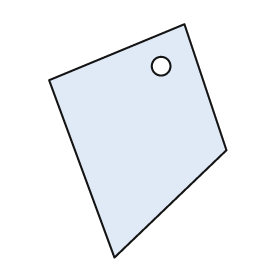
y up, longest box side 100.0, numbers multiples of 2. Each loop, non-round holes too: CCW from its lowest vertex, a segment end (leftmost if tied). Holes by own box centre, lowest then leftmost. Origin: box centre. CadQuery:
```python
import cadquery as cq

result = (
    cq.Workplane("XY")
    .moveTo(-10.0, -50.0)
    .lineTo(38.0, -4.0)
    .lineTo(20.0, 50.0)
    .lineTo(-38.0, 26.0)
    .close()
    .moveTo(10.0, 32.0)
    .circle(4.0)
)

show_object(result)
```